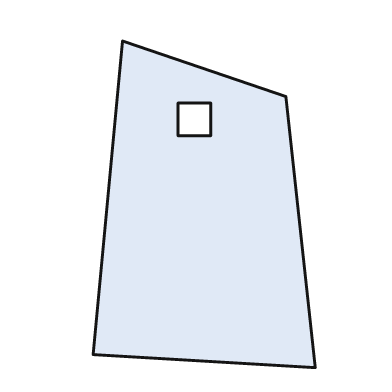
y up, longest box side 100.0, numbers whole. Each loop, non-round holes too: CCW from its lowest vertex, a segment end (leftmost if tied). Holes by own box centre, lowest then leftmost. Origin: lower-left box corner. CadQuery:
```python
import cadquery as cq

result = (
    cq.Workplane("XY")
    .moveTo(68.0, 0.0)
    .lineTo(59.0, 83.0)
    .lineTo(9.0, 100.0)
    .lineTo(0.0, 4.0)
    .close()
    .moveTo(26.0, 71.0)
    .lineTo(36.0, 71.0)
    .lineTo(36.0, 81.0)
    .lineTo(26.0, 81.0)
    .close()
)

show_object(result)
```